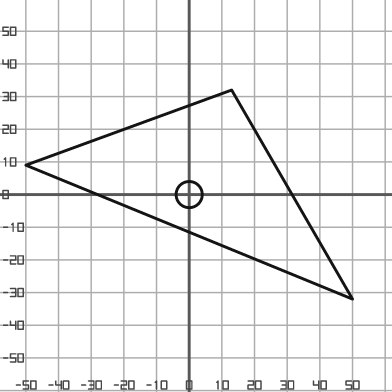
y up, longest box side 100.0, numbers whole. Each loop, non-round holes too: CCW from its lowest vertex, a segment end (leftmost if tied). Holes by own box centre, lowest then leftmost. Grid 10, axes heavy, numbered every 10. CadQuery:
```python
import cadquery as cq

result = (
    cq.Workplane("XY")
    .moveTo(50.0, -32.0)
    .lineTo(13.0, 32.0)
    .lineTo(-50.0, 9.0)
    .close()
    .moveTo(0.0, 0.0)
    .circle(4.0)
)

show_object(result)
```